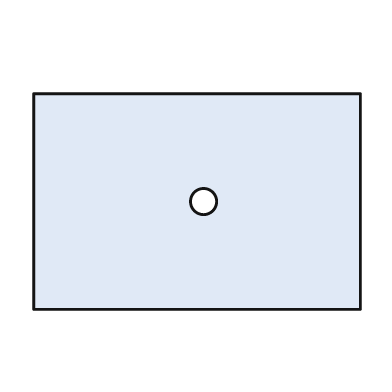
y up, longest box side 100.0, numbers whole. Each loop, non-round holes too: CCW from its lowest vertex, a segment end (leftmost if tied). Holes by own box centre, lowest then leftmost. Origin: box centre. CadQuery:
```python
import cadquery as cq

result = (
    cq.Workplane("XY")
    .moveTo(-50.0, -33.0)
    .lineTo(50.0, -33.0)
    .lineTo(50.0, 33.0)
    .lineTo(-50.0, 33.0)
    .close()
    .moveTo(2.0, 0.0)
    .circle(4.0)
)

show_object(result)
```